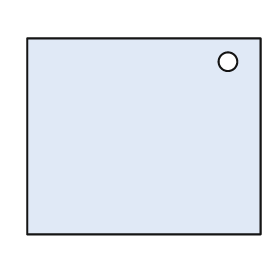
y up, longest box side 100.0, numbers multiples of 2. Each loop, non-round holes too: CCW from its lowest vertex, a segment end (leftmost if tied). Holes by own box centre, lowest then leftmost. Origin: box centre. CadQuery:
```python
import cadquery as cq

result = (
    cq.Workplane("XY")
    .moveTo(-50.0, -42.0)
    .lineTo(50.0, -42.0)
    .lineTo(50.0, 42.0)
    .lineTo(-50.0, 42.0)
    .close()
    .moveTo(36.0, 32.0)
    .circle(4.0)
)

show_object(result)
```